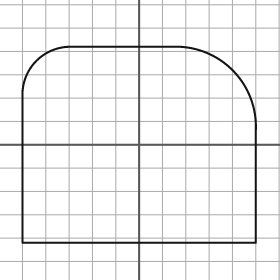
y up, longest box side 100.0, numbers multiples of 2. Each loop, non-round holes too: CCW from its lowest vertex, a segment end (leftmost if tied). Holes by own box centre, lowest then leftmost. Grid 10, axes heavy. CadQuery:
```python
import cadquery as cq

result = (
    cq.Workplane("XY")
    .moveTo(-50.0, -42.0)
    .lineTo(50.0, -42.0)
    .lineTo(50.0, 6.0)
    .threePointArc((40.0, 32.0), (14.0, 42.0))
    .lineTo(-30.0, 42.0)
    .threePointArc((-44.0, 36.0), (-50.0, 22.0))
    .close()
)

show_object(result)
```